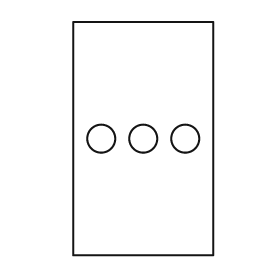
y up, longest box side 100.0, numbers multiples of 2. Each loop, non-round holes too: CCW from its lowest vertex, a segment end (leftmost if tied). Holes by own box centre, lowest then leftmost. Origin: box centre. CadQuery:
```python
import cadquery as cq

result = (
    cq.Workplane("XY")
    .moveTo(-30.0, -50.0)
    .lineTo(30.0, -50.0)
    .lineTo(30.0, 50.0)
    .lineTo(-30.0, 50.0)
    .close()
    .moveTo(-18.0, 0.0)
    .circle(6.0)
    .moveTo(0.0, 0.0)
    .circle(6.0)
    .moveTo(18.0, 0.0)
    .circle(6.0)
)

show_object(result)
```